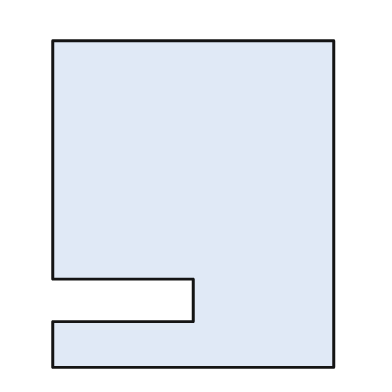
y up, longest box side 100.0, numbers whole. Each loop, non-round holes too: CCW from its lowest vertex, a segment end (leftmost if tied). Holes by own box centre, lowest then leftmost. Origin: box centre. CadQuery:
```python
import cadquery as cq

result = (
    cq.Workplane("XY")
    .moveTo(-43.0, -50.0)
    .lineTo(43.0, -50.0)
    .lineTo(43.0, 50.0)
    .lineTo(-43.0, 50.0)
    .lineTo(-43.0, -23.0)
    .lineTo(0.0, -23.0)
    .lineTo(0.0, -36.0)
    .lineTo(-43.0, -36.0)
    .close()
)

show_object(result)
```